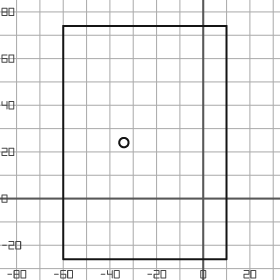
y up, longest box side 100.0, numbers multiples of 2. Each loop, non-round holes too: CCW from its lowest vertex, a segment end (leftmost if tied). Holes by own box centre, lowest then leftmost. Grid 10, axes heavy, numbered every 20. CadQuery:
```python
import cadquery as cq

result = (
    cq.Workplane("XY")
    .moveTo(-60.0, -26.0)
    .lineTo(10.0, -26.0)
    .lineTo(10.0, 74.0)
    .lineTo(-60.0, 74.0)
    .close()
    .moveTo(-34.0, 24.0)
    .circle(2.0)
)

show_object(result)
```